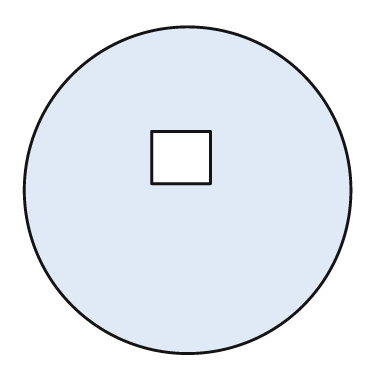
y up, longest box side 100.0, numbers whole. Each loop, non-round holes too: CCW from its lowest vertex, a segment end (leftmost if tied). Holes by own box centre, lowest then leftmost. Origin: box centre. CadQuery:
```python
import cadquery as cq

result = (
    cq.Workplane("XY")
    .moveTo(0.0, 0.0)
    .circle(50.0)
    .moveTo(-11.0, 2.0)
    .lineTo(7.0, 2.0)
    .lineTo(7.0, 18.0)
    .lineTo(-11.0, 18.0)
    .close()
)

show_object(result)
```